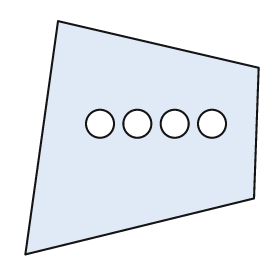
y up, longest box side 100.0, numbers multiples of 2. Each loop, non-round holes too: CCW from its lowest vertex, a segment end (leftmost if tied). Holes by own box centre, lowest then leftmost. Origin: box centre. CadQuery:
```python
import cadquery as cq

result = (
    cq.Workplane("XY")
    .moveTo(-50.0, -50.0)
    .lineTo(48.0, -26.0)
    .lineTo(50.0, 30.0)
    .lineTo(-36.0, 50.0)
    .close()
    .moveTo(-18.0, 6.0)
    .circle(6.0)
    .moveTo(-2.0, 6.0)
    .circle(6.0)
    .moveTo(14.0, 6.0)
    .circle(6.0)
    .moveTo(30.0, 6.0)
    .circle(6.0)
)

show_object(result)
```